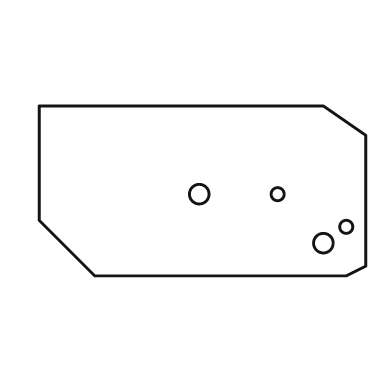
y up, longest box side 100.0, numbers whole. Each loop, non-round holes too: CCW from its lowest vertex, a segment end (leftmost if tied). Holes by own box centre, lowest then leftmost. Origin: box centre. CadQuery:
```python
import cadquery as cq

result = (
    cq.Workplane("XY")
    .moveTo(-33.0, -26.0)
    .lineTo(44.0, -26.0)
    .lineTo(50.0, -23.0)
    .lineTo(50.0, 17.0)
    .lineTo(37.0, 26.0)
    .lineTo(-50.0, 26.0)
    .lineTo(-50.0, -9.0)
    .close()
    .moveTo(37.0, -16.0)
    .circle(3.0)
    .moveTo(44.0, -11.0)
    .circle(2.0)
    .moveTo(-1.0, -1.0)
    .circle(3.0)
    .moveTo(23.0, -1.0)
    .circle(2.0)
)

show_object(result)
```